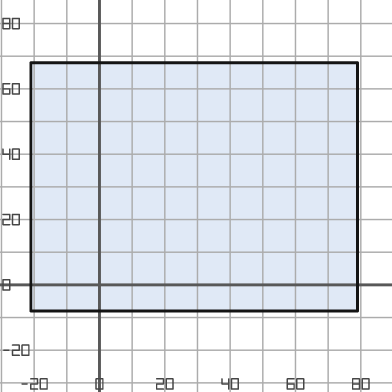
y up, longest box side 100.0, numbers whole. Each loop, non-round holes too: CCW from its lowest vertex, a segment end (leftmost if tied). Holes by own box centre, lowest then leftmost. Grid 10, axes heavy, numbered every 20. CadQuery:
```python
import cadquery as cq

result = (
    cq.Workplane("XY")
    .moveTo(-21.0, -8.0)
    .lineTo(79.0, -8.0)
    .lineTo(79.0, 68.0)
    .lineTo(-21.0, 68.0)
    .close()
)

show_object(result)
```